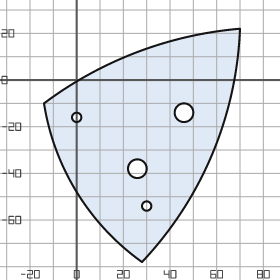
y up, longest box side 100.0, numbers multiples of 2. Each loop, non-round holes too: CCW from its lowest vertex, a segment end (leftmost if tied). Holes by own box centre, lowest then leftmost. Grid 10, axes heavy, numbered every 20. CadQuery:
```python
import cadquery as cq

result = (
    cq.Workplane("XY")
    .moveTo(28.0, -78.0)
    .threePointArc((58.0, -32.0), (70.0, 22.0))
    .threePointArc((26.0, 12.0), (-14.0, -10.0))
    .threePointArc((0.0, -48.0), (28.0, -78.0))
    .close()
    .moveTo(30.0, -54.0)
    .circle(2.0)
    .moveTo(26.0, -38.0)
    .circle(4.0)
    .moveTo(0.0, -16.0)
    .circle(2.0)
    .moveTo(46.0, -14.0)
    .circle(4.0)
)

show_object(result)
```